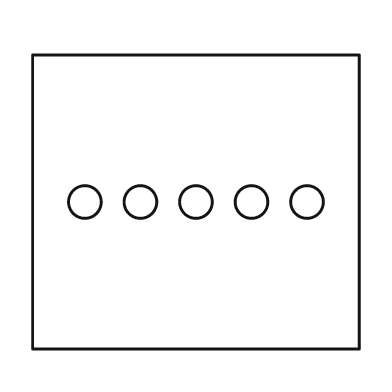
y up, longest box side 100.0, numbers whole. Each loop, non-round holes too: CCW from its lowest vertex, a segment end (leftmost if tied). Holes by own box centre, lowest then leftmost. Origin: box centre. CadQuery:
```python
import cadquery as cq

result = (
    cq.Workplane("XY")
    .moveTo(-50.0, -45.0)
    .lineTo(50.0, -45.0)
    .lineTo(50.0, 45.0)
    .lineTo(-50.0, 45.0)
    .close()
    .moveTo(-34.0, 0.0)
    .circle(5.0)
    .moveTo(-17.0, 0.0)
    .circle(5.0)
    .moveTo(0.0, 0.0)
    .circle(5.0)
    .moveTo(17.0, 0.0)
    .circle(5.0)
    .moveTo(34.0, 0.0)
    .circle(5.0)
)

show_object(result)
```